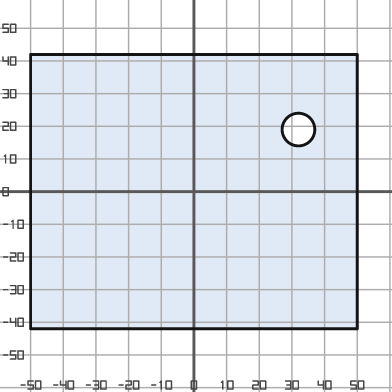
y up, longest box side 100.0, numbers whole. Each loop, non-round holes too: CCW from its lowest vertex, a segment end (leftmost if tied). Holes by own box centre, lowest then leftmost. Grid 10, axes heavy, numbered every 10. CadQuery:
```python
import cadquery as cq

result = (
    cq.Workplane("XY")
    .moveTo(-50.0, -42.0)
    .lineTo(50.0, -42.0)
    .lineTo(50.0, 42.0)
    .lineTo(-50.0, 42.0)
    .close()
    .moveTo(32.0, 19.0)
    .circle(5.0)
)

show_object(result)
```